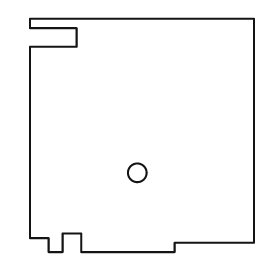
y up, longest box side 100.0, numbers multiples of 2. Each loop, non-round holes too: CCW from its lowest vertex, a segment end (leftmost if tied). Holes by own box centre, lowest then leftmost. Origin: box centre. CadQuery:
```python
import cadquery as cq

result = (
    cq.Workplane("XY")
    .moveTo(-40.0, -50.0)
    .lineTo(-34.0, -50.0)
    .lineTo(-34.0, -42.0)
    .lineTo(-26.0, -42.0)
    .lineTo(-26.0, -50.0)
    .lineTo(14.0, -50.0)
    .lineTo(14.0, -46.0)
    .lineTo(48.0, -46.0)
    .lineTo(48.0, 50.0)
    .lineTo(-48.0, 50.0)
    .lineTo(-48.0, 46.0)
    .lineTo(-28.0, 46.0)
    .lineTo(-28.0, 38.0)
    .lineTo(-48.0, 38.0)
    .lineTo(-48.0, -44.0)
    .lineTo(-40.0, -44.0)
    .close()
    .moveTo(-2.0, -16.0)
    .circle(4.0)
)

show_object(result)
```